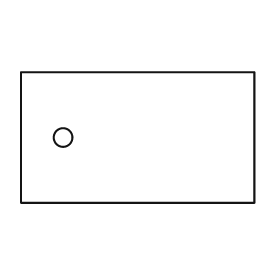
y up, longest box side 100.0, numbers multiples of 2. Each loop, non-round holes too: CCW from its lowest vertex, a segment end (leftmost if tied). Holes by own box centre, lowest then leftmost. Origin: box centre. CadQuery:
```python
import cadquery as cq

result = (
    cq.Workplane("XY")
    .moveTo(-50.0, -28.0)
    .lineTo(50.0, -28.0)
    .lineTo(50.0, 28.0)
    .lineTo(-50.0, 28.0)
    .close()
    .moveTo(-32.0, 0.0)
    .circle(4.0)
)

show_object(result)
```